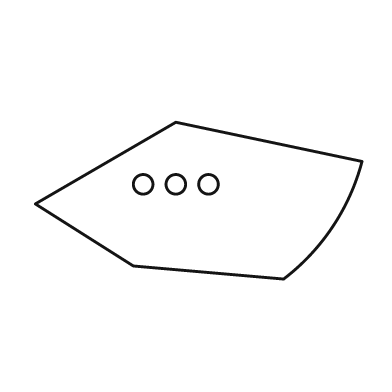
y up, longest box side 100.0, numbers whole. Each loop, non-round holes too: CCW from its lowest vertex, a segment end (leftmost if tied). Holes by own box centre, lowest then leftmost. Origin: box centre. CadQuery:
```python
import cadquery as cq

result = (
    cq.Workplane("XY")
    .moveTo(26.0, -24.0)
    .threePointArc((41.0, -8.0), (50.0, 12.0))
    .lineTo(-7.0, 24.0)
    .lineTo(-50.0, -1.0)
    .lineTo(-20.0, -20.0)
    .close()
    .moveTo(-17.0, 5.0)
    .circle(3.0)
    .moveTo(-7.0, 5.0)
    .circle(3.0)
    .moveTo(3.0, 5.0)
    .circle(3.0)
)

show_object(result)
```